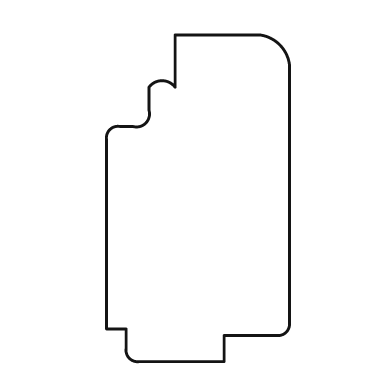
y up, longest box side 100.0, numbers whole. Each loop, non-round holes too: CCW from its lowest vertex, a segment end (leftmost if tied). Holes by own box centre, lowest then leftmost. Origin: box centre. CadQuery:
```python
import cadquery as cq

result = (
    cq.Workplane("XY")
    .moveTo(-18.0, -50.0)
    .lineTo(8.0, -50.0)
    .lineTo(8.0, -42.0)
    .lineTo(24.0, -42.0)
    .threePointArc((27.0, -41.0), (28.0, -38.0))
    .lineTo(28.0, 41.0)
    .threePointArc((25.0, 47.0), (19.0, 50.0))
    .lineTo(-7.0, 50.0)
    .lineTo(-7.0, 34.0)
    .threePointArc((-11.0, 36.0), (-15.0, 34.0))
    .lineTo(-15.0, 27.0)
    .threePointArc((-16.0, 23.0), (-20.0, 22.0))
    .lineTo(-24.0, 22.0)
    .threePointArc((-27.0, 21.0), (-28.0, 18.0))
    .lineTo(-28.0, -40.0)
    .lineTo(-22.0, -40.0)
    .lineTo(-22.0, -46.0)
    .threePointArc((-21.0, -49.0), (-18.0, -50.0))
    .close()
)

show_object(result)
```